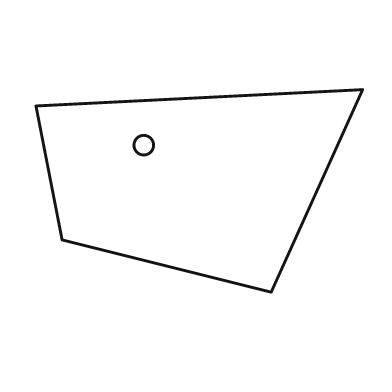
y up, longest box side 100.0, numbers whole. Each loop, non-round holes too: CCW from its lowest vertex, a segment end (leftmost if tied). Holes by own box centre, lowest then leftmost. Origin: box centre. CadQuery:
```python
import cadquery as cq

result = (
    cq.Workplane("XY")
    .moveTo(22.0, -31.0)
    .lineTo(50.0, 31.0)
    .lineTo(-50.0, 26.0)
    .lineTo(-42.0, -15.0)
    .close()
    .moveTo(-17.0, 14.0)
    .circle(3.0)
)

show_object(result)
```